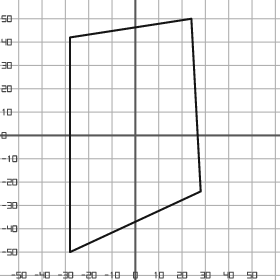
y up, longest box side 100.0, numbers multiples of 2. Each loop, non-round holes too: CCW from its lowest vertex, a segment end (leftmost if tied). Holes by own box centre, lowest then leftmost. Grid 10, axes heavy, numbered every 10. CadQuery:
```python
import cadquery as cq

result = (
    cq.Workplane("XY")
    .moveTo(-28.0, -50.0)
    .lineTo(28.0, -24.0)
    .lineTo(24.0, 50.0)
    .lineTo(-28.0, 42.0)
    .close()
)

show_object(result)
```